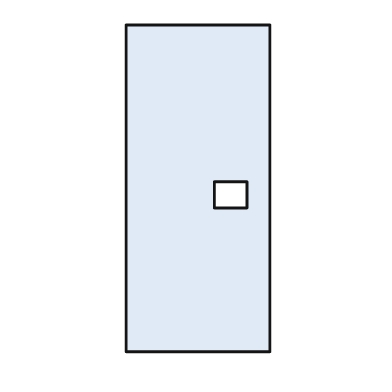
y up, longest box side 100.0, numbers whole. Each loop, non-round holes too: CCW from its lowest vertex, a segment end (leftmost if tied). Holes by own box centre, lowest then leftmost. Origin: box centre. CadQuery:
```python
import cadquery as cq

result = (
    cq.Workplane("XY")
    .moveTo(-22.0, -50.0)
    .lineTo(22.0, -50.0)
    .lineTo(22.0, 50.0)
    .lineTo(-22.0, 50.0)
    .close()
    .moveTo(5.0, -6.0)
    .lineTo(15.0, -6.0)
    .lineTo(15.0, 2.0)
    .lineTo(5.0, 2.0)
    .close()
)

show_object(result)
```